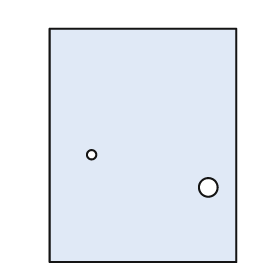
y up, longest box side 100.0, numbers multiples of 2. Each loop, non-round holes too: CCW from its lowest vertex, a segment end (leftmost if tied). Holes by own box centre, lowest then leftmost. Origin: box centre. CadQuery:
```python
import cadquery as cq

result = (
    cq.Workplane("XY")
    .moveTo(-40.0, -50.0)
    .lineTo(40.0, -50.0)
    .lineTo(40.0, 50.0)
    .lineTo(-40.0, 50.0)
    .close()
    .moveTo(28.0, -18.0)
    .circle(4.0)
    .moveTo(-22.0, -4.0)
    .circle(2.0)
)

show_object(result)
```